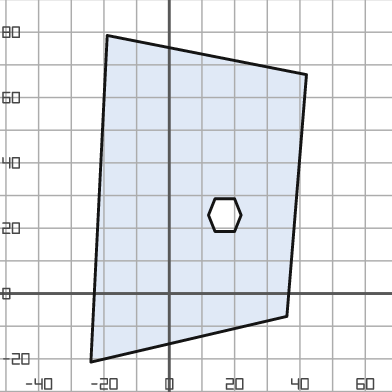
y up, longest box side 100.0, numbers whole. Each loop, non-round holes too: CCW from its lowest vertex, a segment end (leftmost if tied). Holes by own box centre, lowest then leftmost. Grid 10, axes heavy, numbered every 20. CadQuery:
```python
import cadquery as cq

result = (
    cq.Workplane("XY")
    .moveTo(-24.0, -21.0)
    .lineTo(36.0, -7.0)
    .lineTo(42.0, 67.0)
    .lineTo(-19.0, 79.0)
    .close()
    .moveTo(14.0, 19.0)
    .lineTo(20.0, 19.0)
    .lineTo(22.0, 24.0)
    .lineTo(20.0, 29.0)
    .lineTo(14.0, 29.0)
    .lineTo(12.0, 24.0)
    .close()
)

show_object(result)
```